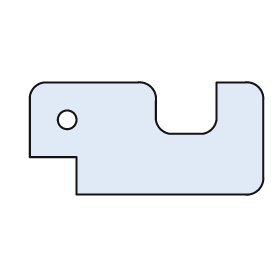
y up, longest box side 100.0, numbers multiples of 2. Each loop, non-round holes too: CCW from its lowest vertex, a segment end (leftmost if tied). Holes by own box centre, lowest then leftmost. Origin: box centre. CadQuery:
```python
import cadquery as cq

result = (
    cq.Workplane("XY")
    .moveTo(-30.0, -24.0)
    .lineTo(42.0, -24.0)
    .threePointArc((48.0, -22.0), (50.0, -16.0))
    .lineTo(50.0, 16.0)
    .threePointArc((48.0, 22.0), (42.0, 24.0))
    .lineTo(30.0, 24.0)
    .lineTo(30.0, 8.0)
    .threePointArc((28.0, 4.0), (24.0, 2.0))
    .lineTo(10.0, 2.0)
    .threePointArc((6.0, 4.0), (4.0, 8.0))
    .lineTo(4.0, 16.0)
    .threePointArc((2.0, 22.0), (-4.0, 24.0))
    .lineTo(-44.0, 24.0)
    .threePointArc((-48.0, 22.0), (-50.0, 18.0))
    .lineTo(-50.0, -8.0)
    .lineTo(-30.0, -8.0)
    .close()
    .moveTo(-34.0, 8.0)
    .circle(4.0)
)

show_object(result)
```